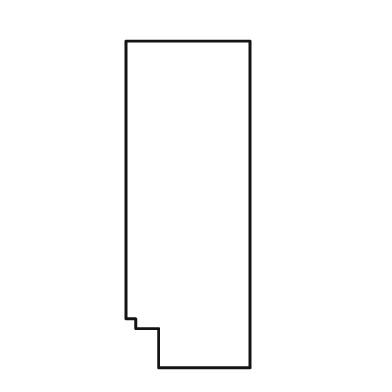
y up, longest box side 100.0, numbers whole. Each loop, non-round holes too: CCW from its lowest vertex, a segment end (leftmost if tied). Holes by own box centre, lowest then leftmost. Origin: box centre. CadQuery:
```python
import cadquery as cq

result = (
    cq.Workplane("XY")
    .moveTo(-9.0, -50.0)
    .lineTo(19.0, -50.0)
    .lineTo(19.0, 50.0)
    .lineTo(-19.0, 50.0)
    .lineTo(-19.0, -35.0)
    .lineTo(-16.0, -35.0)
    .lineTo(-16.0, -38.0)
    .lineTo(-9.0, -38.0)
    .close()
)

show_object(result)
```